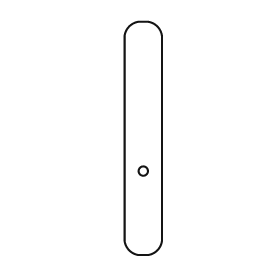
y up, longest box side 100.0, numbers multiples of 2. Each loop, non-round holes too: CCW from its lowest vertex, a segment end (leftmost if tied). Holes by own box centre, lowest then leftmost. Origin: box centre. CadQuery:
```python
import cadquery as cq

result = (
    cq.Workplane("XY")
    .moveTo(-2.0, -50.0)
    .lineTo(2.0, -50.0)
    .threePointArc((6.0, -48.0), (8.0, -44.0))
    .lineTo(8.0, 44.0)
    .threePointArc((6.0, 48.0), (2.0, 50.0))
    .lineTo(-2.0, 50.0)
    .threePointArc((-6.0, 48.0), (-8.0, 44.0))
    .lineTo(-8.0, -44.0)
    .threePointArc((-6.0, -48.0), (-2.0, -50.0))
    .close()
    .moveTo(0.0, -14.0)
    .circle(2.0)
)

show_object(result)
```